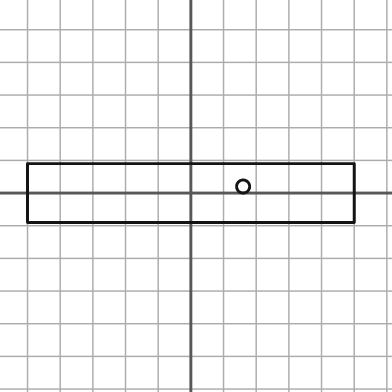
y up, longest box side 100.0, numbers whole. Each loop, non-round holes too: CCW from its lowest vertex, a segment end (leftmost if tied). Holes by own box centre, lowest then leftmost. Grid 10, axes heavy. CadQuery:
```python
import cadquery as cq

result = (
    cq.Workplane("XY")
    .moveTo(-50.0, -9.0)
    .lineTo(50.0, -9.0)
    .lineTo(50.0, 9.0)
    .lineTo(-50.0, 9.0)
    .close()
    .moveTo(16.0, 2.0)
    .circle(2.0)
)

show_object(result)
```